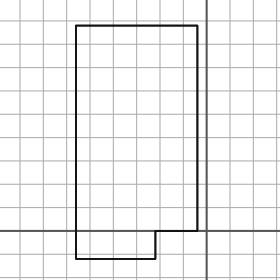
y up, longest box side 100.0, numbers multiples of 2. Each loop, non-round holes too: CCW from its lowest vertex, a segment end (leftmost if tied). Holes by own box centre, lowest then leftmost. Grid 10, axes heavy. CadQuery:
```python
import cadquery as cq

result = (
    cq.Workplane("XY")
    .moveTo(-56.0, -12.0)
    .lineTo(-22.0, -12.0)
    .lineTo(-22.0, 0.0)
    .lineTo(-4.0, 0.0)
    .lineTo(-4.0, 88.0)
    .lineTo(-56.0, 88.0)
    .close()
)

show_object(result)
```